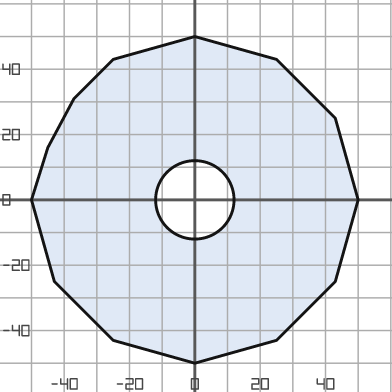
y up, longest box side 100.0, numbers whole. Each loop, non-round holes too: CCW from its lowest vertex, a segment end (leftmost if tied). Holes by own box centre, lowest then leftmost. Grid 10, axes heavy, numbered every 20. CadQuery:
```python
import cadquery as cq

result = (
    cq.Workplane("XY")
    .moveTo(0.0, -50.0)
    .lineTo(25.0, -43.0)
    .lineTo(43.0, -25.0)
    .lineTo(50.0, 0.0)
    .lineTo(43.0, 25.0)
    .lineTo(25.0, 43.0)
    .lineTo(0.0, 50.0)
    .lineTo(-25.0, 43.0)
    .lineTo(-37.0, 31.0)
    .lineTo(-45.0, 16.0)
    .lineTo(-50.0, 0.0)
    .lineTo(-43.0, -25.0)
    .lineTo(-25.0, -43.0)
    .close()
    .moveTo(0.0, 0.0)
    .circle(12.0)
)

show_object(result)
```